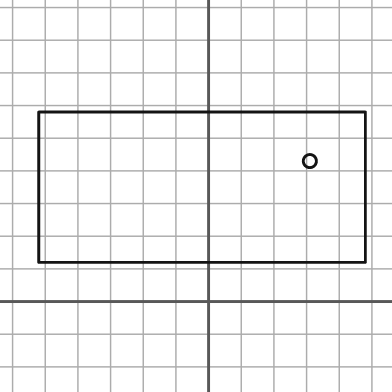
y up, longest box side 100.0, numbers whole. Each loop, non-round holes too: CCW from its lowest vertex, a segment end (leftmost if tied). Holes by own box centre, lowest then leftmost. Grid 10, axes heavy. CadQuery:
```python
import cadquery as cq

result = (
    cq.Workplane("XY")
    .moveTo(-52.0, 12.0)
    .lineTo(48.0, 12.0)
    .lineTo(48.0, 58.0)
    .lineTo(-52.0, 58.0)
    .close()
    .moveTo(31.0, 43.0)
    .circle(2.0)
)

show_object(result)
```